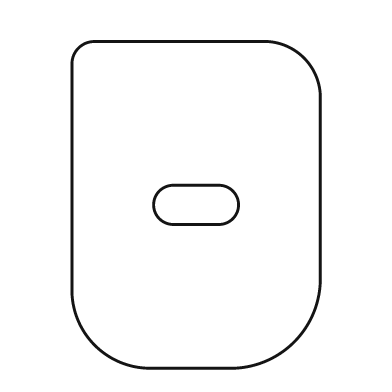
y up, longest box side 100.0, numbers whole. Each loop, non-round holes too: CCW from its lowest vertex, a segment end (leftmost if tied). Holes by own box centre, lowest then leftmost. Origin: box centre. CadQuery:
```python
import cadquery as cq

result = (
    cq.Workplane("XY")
    .moveTo(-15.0, -50.0)
    .lineTo(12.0, -50.0)
    .threePointArc((30.0, -42.0), (38.0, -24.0))
    .lineTo(38.0, 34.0)
    .threePointArc((33.0, 45.0), (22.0, 50.0))
    .lineTo(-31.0, 50.0)
    .threePointArc((-36.0, 48.0), (-38.0, 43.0))
    .lineTo(-38.0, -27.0)
    .threePointArc((-31.0, -43.0), (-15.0, -50.0))
    .close()
    .moveTo(-7.0, -6.0)
    .lineTo(7.0, -6.0)
    .threePointArc((13.0, 0.0), (7.0, 6.0))
    .lineTo(-7.0, 6.0)
    .threePointArc((-13.0, 0.0), (-7.0, -6.0))
    .close()
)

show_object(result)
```